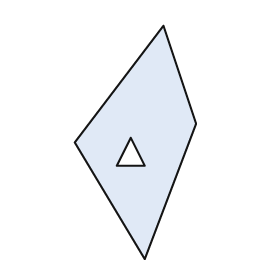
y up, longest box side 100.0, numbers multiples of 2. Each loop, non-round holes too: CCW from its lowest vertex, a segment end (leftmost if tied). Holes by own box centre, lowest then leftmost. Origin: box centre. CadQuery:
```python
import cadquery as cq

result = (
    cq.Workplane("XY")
    .moveTo(4.0, -50.0)
    .lineTo(26.0, 8.0)
    .lineTo(12.0, 50.0)
    .lineTo(-26.0, 0.0)
    .close()
    .moveTo(-8.0, -10.0)
    .lineTo(4.0, -10.0)
    .lineTo(-2.0, 2.0)
    .close()
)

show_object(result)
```